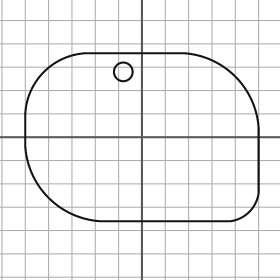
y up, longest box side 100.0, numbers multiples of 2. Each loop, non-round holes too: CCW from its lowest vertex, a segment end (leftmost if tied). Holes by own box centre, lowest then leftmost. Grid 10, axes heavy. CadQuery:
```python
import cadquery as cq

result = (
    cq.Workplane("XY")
    .moveTo(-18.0, -36.0)
    .lineTo(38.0, -36.0)
    .threePointArc((46.0, -32.0), (50.0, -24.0))
    .lineTo(50.0, 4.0)
    .threePointArc((40.0, 26.0), (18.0, 36.0))
    .lineTo(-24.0, 36.0)
    .threePointArc((-42.0, 28.0), (-50.0, 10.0))
    .lineTo(-50.0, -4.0)
    .threePointArc((-40.0, -26.0), (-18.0, -36.0))
    .close()
    .moveTo(-8.0, 28.0)
    .circle(4.0)
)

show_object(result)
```